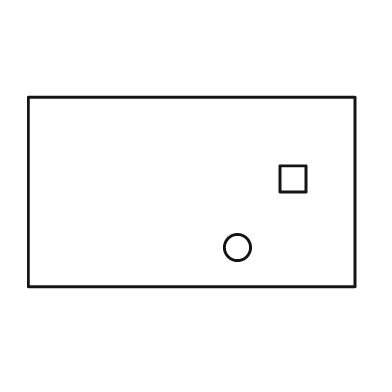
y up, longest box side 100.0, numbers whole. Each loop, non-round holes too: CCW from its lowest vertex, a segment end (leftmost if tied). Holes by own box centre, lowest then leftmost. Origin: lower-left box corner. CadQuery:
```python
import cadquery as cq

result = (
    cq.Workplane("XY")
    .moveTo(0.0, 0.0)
    .lineTo(100.0, 0.0)
    .lineTo(100.0, 58.0)
    .lineTo(0.0, 58.0)
    .close()
    .moveTo(64.0, 12.0)
    .circle(4.0)
    .moveTo(77.0, 29.0)
    .lineTo(85.0, 29.0)
    .lineTo(85.0, 37.0)
    .lineTo(77.0, 37.0)
    .close()
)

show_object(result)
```